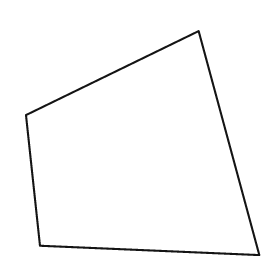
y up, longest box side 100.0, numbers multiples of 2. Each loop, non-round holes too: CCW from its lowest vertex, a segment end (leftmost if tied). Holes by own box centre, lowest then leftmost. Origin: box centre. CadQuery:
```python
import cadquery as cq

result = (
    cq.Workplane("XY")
    .moveTo(50.0, -48.0)
    .lineTo(24.0, 48.0)
    .lineTo(-50.0, 12.0)
    .lineTo(-44.0, -44.0)
    .close()
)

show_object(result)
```